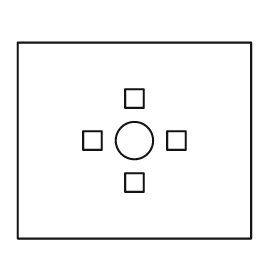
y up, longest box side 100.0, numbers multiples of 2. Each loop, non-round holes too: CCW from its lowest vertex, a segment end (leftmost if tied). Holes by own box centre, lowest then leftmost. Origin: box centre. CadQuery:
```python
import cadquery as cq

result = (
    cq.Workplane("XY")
    .moveTo(-50.0, -42.0)
    .lineTo(50.0, -42.0)
    .lineTo(50.0, 42.0)
    .lineTo(-50.0, 42.0)
    .close()
    .moveTo(-4.0, -22.0)
    .lineTo(4.0, -22.0)
    .lineTo(4.0, -14.0)
    .lineTo(-4.0, -14.0)
    .close()
    .moveTo(-22.0, -4.0)
    .lineTo(-14.0, -4.0)
    .lineTo(-14.0, 4.0)
    .lineTo(-22.0, 4.0)
    .close()
    .moveTo(0.0, 0.0)
    .circle(8.0)
    .moveTo(14.0, -4.0)
    .lineTo(22.0, -4.0)
    .lineTo(22.0, 4.0)
    .lineTo(14.0, 4.0)
    .close()
    .moveTo(-4.0, 14.0)
    .lineTo(4.0, 14.0)
    .lineTo(4.0, 22.0)
    .lineTo(-4.0, 22.0)
    .close()
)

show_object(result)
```